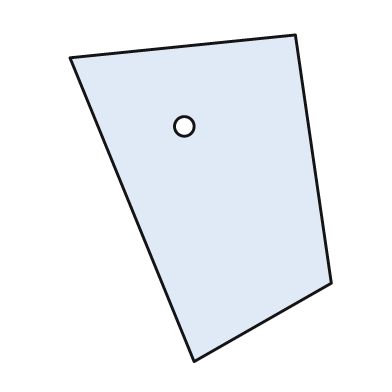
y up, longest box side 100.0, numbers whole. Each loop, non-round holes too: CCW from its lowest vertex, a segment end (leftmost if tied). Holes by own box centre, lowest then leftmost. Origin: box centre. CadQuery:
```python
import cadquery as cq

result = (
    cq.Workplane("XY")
    .moveTo(-2.0, -50.0)
    .lineTo(40.0, -26.0)
    .lineTo(29.0, 50.0)
    .lineTo(-40.0, 43.0)
    .close()
    .moveTo(-5.0, 22.0)
    .circle(3.0)
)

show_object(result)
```